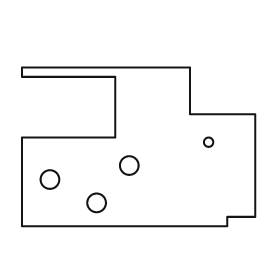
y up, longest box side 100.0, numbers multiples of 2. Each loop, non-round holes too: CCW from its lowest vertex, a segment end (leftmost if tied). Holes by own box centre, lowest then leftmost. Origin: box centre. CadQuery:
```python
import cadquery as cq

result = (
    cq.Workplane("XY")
    .moveTo(-50.0, -34.0)
    .lineTo(38.0, -34.0)
    .lineTo(38.0, -30.0)
    .lineTo(50.0, -30.0)
    .lineTo(50.0, 14.0)
    .lineTo(22.0, 14.0)
    .lineTo(22.0, 34.0)
    .lineTo(-50.0, 34.0)
    .lineTo(-50.0, 30.0)
    .lineTo(-10.0, 30.0)
    .lineTo(-10.0, 4.0)
    .lineTo(-50.0, 4.0)
    .close()
    .moveTo(-18.0, -24.0)
    .circle(4.0)
    .moveTo(-38.0, -14.0)
    .circle(4.0)
    .moveTo(-4.0, -8.0)
    .circle(4.0)
    .moveTo(30.0, 2.0)
    .circle(2.0)
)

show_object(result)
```